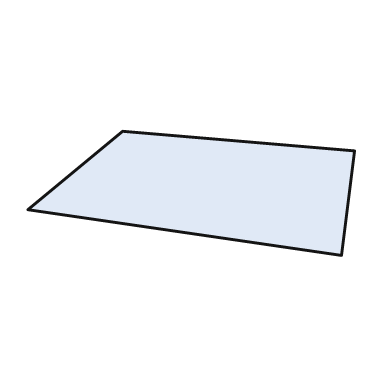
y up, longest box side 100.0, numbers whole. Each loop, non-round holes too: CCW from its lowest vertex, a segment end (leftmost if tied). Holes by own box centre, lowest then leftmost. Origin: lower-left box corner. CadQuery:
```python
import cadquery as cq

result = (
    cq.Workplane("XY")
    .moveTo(96.0, 0.0)
    .lineTo(100.0, 32.0)
    .lineTo(29.0, 38.0)
    .lineTo(0.0, 14.0)
    .close()
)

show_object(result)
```